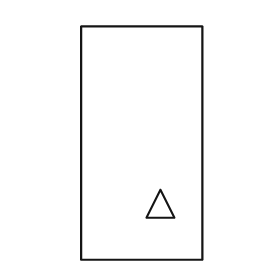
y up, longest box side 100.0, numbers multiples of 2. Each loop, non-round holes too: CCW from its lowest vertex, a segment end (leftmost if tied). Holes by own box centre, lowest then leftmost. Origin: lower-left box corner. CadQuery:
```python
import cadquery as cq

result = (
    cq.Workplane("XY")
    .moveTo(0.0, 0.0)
    .lineTo(52.0, 0.0)
    .lineTo(52.0, 100.0)
    .lineTo(0.0, 100.0)
    .close()
    .moveTo(28.0, 18.0)
    .lineTo(40.0, 18.0)
    .lineTo(34.0, 30.0)
    .close()
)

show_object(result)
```